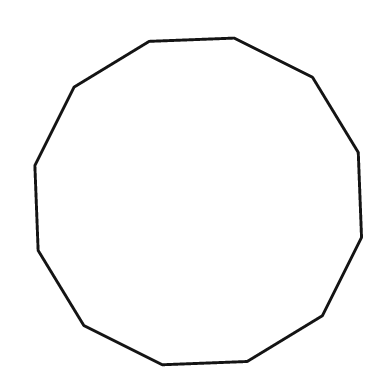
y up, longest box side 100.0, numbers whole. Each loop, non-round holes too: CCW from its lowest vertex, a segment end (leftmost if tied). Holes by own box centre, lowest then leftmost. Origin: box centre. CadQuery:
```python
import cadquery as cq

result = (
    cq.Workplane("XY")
    .moveTo(-11.0, -50.0)
    .lineTo(15.0, -49.0)
    .lineTo(38.0, -35.0)
    .lineTo(50.0, -11.0)
    .lineTo(49.0, 15.0)
    .lineTo(35.0, 38.0)
    .lineTo(11.0, 50.0)
    .lineTo(-15.0, 49.0)
    .lineTo(-38.0, 35.0)
    .lineTo(-50.0, 11.0)
    .lineTo(-49.0, -15.0)
    .lineTo(-35.0, -38.0)
    .close()
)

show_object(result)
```